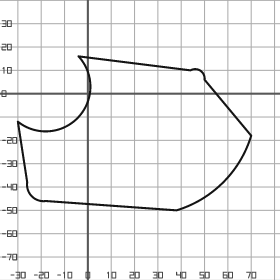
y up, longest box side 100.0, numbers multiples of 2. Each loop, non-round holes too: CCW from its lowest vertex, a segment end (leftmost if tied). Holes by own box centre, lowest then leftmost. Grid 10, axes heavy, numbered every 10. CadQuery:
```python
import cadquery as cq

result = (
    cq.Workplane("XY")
    .moveTo(38.0, -50.0)
    .threePointArc((58.0, -38.0), (70.0, -18.0))
    .lineTo(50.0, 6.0)
    .threePointArc((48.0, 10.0), (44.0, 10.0))
    .lineTo(-4.0, 16.0)
    .threePointArc((-4.0, -10.0), (-30.0, -12.0))
    .lineTo(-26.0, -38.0)
    .threePointArc((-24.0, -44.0), (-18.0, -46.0))
    .close()
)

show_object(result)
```